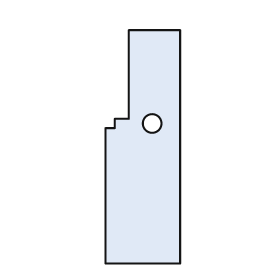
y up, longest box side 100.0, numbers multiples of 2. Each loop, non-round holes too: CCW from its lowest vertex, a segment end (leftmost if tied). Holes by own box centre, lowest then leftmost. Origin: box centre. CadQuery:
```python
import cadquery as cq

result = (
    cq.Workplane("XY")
    .moveTo(-16.0, -50.0)
    .lineTo(16.0, -50.0)
    .lineTo(16.0, 50.0)
    .lineTo(-6.0, 50.0)
    .lineTo(-6.0, 12.0)
    .lineTo(-12.0, 12.0)
    .lineTo(-12.0, 8.0)
    .lineTo(-16.0, 8.0)
    .close()
    .moveTo(4.0, 10.0)
    .circle(4.0)
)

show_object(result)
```